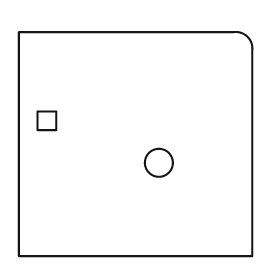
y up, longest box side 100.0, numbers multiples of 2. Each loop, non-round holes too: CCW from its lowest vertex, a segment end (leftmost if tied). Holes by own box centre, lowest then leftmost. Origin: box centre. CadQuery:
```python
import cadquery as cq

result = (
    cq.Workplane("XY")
    .moveTo(-50.0, -48.0)
    .lineTo(50.0, -48.0)
    .lineTo(50.0, 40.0)
    .threePointArc((48.0, 46.0), (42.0, 48.0))
    .lineTo(-50.0, 48.0)
    .close()
    .moveTo(10.0, -8.0)
    .circle(6.0)
    .moveTo(-42.0, 6.0)
    .lineTo(-34.0, 6.0)
    .lineTo(-34.0, 14.0)
    .lineTo(-42.0, 14.0)
    .close()
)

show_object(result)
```